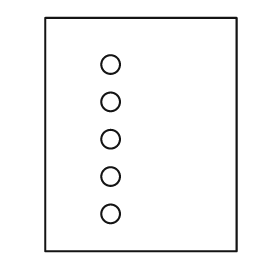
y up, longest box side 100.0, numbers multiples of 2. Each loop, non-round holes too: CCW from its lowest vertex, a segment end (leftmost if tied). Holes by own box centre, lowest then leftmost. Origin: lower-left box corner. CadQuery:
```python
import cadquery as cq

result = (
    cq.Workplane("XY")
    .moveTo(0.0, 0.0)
    .lineTo(82.0, 0.0)
    .lineTo(82.0, 100.0)
    .lineTo(0.0, 100.0)
    .close()
    .moveTo(28.0, 16.0)
    .circle(4.0)
    .moveTo(28.0, 32.0)
    .circle(4.0)
    .moveTo(28.0, 48.0)
    .circle(4.0)
    .moveTo(28.0, 64.0)
    .circle(4.0)
    .moveTo(28.0, 80.0)
    .circle(4.0)
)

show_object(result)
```